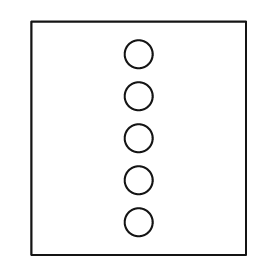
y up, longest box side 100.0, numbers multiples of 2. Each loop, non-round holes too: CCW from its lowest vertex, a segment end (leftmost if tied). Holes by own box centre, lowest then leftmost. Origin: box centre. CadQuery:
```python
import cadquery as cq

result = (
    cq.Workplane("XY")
    .moveTo(-46.0, -50.0)
    .lineTo(46.0, -50.0)
    .lineTo(46.0, 50.0)
    .lineTo(-46.0, 50.0)
    .close()
    .moveTo(0.0, -36.0)
    .circle(6.0)
    .moveTo(0.0, -18.0)
    .circle(6.0)
    .moveTo(0.0, 0.0)
    .circle(6.0)
    .moveTo(0.0, 18.0)
    .circle(6.0)
    .moveTo(0.0, 36.0)
    .circle(6.0)
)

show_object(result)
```